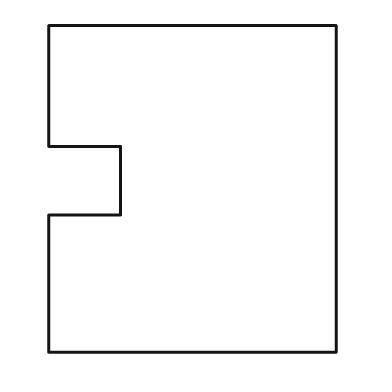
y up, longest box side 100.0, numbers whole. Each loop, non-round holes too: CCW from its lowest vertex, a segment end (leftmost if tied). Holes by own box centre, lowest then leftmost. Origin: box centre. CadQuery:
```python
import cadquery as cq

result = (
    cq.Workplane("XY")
    .moveTo(-44.0, -50.0)
    .lineTo(44.0, -50.0)
    .lineTo(44.0, 50.0)
    .lineTo(-44.0, 50.0)
    .lineTo(-44.0, 13.0)
    .lineTo(-22.0, 13.0)
    .lineTo(-22.0, -8.0)
    .lineTo(-44.0, -8.0)
    .close()
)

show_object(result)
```